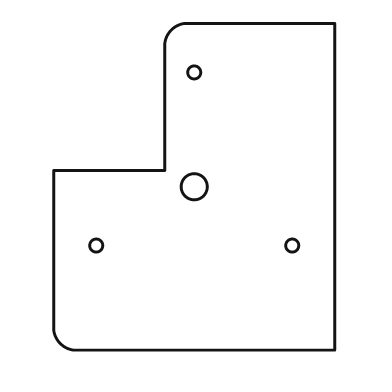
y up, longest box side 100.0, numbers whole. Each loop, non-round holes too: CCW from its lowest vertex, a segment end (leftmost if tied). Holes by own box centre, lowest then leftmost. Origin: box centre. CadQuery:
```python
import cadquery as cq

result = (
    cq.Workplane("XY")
    .moveTo(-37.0, -50.0)
    .lineTo(43.0, -50.0)
    .lineTo(43.0, 50.0)
    .lineTo(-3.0, 50.0)
    .threePointArc((-7.0, 48.0), (-9.0, 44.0))
    .lineTo(-9.0, 5.0)
    .lineTo(-43.0, 5.0)
    .lineTo(-43.0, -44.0)
    .threePointArc((-41.0, -48.0), (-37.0, -50.0))
    .close()
    .moveTo(-30.0, -18.0)
    .circle(2.0)
    .moveTo(30.0, -18.0)
    .circle(2.0)
    .moveTo(0.0, 0.0)
    .circle(4.0)
    .moveTo(0.0, 35.0)
    .circle(2.0)
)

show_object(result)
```